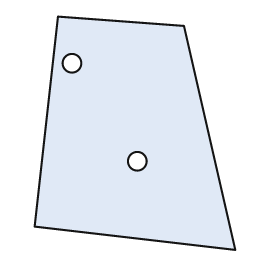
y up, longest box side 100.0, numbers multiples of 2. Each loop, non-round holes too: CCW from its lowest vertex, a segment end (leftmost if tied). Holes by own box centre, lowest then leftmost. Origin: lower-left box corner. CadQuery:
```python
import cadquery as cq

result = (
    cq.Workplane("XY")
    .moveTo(86.0, 0.0)
    .lineTo(64.0, 96.0)
    .lineTo(10.0, 100.0)
    .lineTo(0.0, 10.0)
    .close()
    .moveTo(44.0, 38.0)
    .circle(4.0)
    .moveTo(16.0, 80.0)
    .circle(4.0)
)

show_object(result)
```